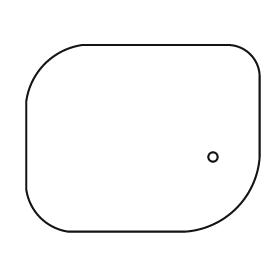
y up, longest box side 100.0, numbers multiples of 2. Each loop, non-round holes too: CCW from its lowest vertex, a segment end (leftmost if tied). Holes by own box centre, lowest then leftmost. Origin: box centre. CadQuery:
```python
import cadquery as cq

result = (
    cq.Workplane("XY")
    .moveTo(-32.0, -40.0)
    .lineTo(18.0, -40.0)
    .threePointArc((40.0, -30.0), (50.0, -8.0))
    .lineTo(50.0, 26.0)
    .threePointArc((46.0, 36.0), (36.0, 40.0))
    .lineTo(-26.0, 40.0)
    .threePointArc((-42.0, 32.0), (-50.0, 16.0))
    .lineTo(-50.0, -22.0)
    .threePointArc((-44.0, -34.0), (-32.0, -40.0))
    .close()
    .moveTo(30.0, -8.0)
    .circle(2.0)
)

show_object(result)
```